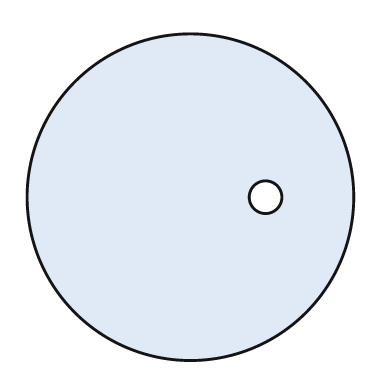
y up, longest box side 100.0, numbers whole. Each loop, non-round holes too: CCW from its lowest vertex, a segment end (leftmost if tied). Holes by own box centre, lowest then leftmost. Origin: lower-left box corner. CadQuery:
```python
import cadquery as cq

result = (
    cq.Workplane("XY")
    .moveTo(50.0, 50.0)
    .circle(50.0)
    .moveTo(73.0, 50.0)
    .circle(5.0)
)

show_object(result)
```